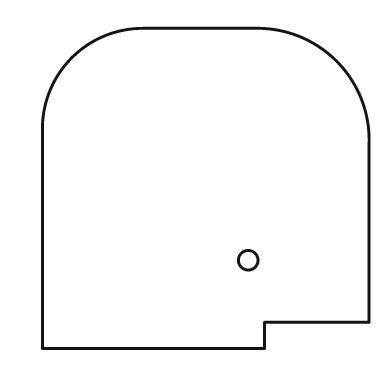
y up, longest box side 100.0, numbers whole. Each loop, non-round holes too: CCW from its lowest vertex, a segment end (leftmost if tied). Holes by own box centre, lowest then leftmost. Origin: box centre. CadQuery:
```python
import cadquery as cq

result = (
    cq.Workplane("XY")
    .moveTo(-50.0, -49.0)
    .lineTo(18.0, -49.0)
    .lineTo(18.0, -41.0)
    .lineTo(50.0, -41.0)
    .lineTo(50.0, 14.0)
    .threePointArc((40.0, 39.0), (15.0, 49.0))
    .lineTo(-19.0, 49.0)
    .threePointArc((-41.0, 40.0), (-50.0, 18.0))
    .close()
    .moveTo(13.0, -22.0)
    .circle(3.0)
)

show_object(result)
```